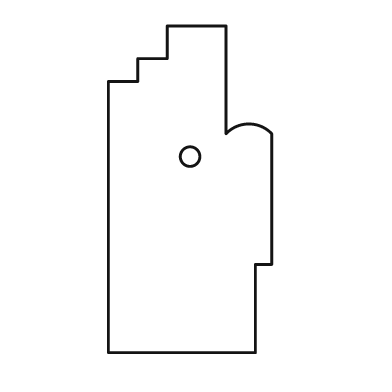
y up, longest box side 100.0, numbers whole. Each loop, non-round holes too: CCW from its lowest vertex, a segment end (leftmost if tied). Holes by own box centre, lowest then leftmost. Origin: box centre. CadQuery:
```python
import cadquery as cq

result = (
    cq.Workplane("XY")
    .moveTo(-25.0, -50.0)
    .lineTo(20.0, -50.0)
    .lineTo(20.0, -23.0)
    .lineTo(25.0, -23.0)
    .lineTo(25.0, 17.0)
    .threePointArc((18.0, 20.0), (11.0, 17.0))
    .lineTo(11.0, 50.0)
    .lineTo(-7.0, 50.0)
    .lineTo(-7.0, 40.0)
    .lineTo(-16.0, 40.0)
    .lineTo(-16.0, 33.0)
    .lineTo(-25.0, 33.0)
    .close()
    .moveTo(0.0, 10.0)
    .circle(3.0)
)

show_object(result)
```